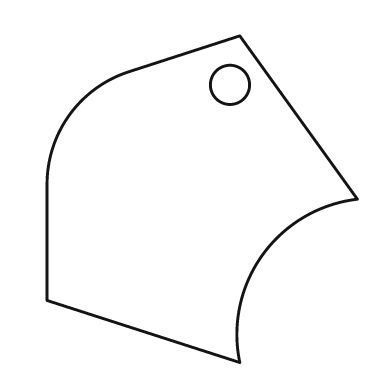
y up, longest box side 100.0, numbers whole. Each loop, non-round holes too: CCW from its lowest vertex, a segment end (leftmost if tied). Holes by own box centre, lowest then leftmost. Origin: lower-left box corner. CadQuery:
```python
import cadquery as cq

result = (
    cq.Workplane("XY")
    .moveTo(59.0, 0.0)
    .threePointArc((66.0, 33.0), (95.0, 50.0))
    .lineTo(59.0, 100.0)
    .lineTo(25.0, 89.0)
    .threePointArc((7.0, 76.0), (0.0, 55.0))
    .lineTo(0.0, 19.0)
    .close()
    .moveTo(56.0, 85.0)
    .circle(6.0)
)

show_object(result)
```